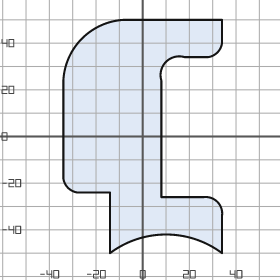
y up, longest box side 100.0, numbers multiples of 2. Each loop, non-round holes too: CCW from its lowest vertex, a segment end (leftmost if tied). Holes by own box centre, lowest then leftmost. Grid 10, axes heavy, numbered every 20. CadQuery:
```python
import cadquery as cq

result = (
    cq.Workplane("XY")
    .moveTo(-14.0, -50.0)
    .threePointArc((10.0, -42.0), (34.0, -50.0))
    .lineTo(34.0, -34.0)
    .threePointArc((32.0, -28.0), (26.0, -26.0))
    .lineTo(8.0, -26.0)
    .lineTo(8.0, 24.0)
    .threePointArc((10.0, 32.0), (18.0, 34.0))
    .lineTo(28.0, 34.0)
    .threePointArc((32.0, 36.0), (34.0, 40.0))
    .lineTo(34.0, 50.0)
    .lineTo(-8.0, 50.0)
    .threePointArc((-26.0, 42.0), (-34.0, 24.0))
    .lineTo(-34.0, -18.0)
    .threePointArc((-32.0, -22.0), (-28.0, -24.0))
    .lineTo(-14.0, -24.0)
    .close()
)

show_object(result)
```